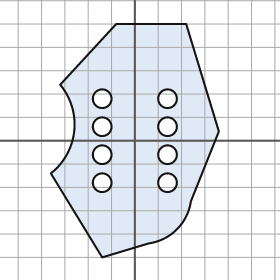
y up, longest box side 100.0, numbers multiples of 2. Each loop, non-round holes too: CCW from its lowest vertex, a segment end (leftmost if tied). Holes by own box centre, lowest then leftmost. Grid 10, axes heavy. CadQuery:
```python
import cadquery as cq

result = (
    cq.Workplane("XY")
    .moveTo(-14.0, -50.0)
    .lineTo(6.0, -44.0)
    .threePointArc((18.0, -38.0), (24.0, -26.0))
    .lineTo(36.0, 4.0)
    .lineTo(22.0, 50.0)
    .lineTo(-8.0, 50.0)
    .lineTo(-32.0, 24.0)
    .threePointArc((-26.0, 4.0), (-36.0, -14.0))
    .close()
    .moveTo(-14.0, -18.0)
    .circle(4.0)
    .moveTo(14.0, -18.0)
    .circle(4.0)
    .moveTo(-14.0, -6.0)
    .circle(4.0)
    .moveTo(14.0, -6.0)
    .circle(4.0)
    .moveTo(-14.0, 6.0)
    .circle(4.0)
    .moveTo(14.0, 6.0)
    .circle(4.0)
    .moveTo(-14.0, 18.0)
    .circle(4.0)
    .moveTo(14.0, 18.0)
    .circle(4.0)
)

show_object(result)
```